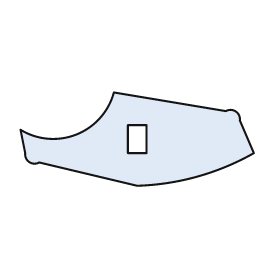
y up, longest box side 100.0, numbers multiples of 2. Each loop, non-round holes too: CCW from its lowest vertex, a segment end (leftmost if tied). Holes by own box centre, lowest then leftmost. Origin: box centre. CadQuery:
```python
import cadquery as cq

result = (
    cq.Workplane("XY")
    .moveTo(0.0, -20.0)
    .threePointArc((26.0, -16.0), (50.0, -6.0))
    .lineTo(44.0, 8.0)
    .threePointArc((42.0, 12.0), (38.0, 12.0))
    .lineTo(-10.0, 20.0)
    .threePointArc((-26.0, 2.0), (-50.0, 4.0))
    .lineTo(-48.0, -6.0)
    .threePointArc((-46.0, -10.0), (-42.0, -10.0))
    .close()
    .moveTo(-4.0, -6.0)
    .lineTo(4.0, -6.0)
    .lineTo(4.0, 6.0)
    .lineTo(-4.0, 6.0)
    .close()
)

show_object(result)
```